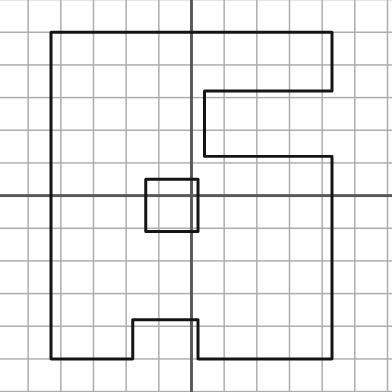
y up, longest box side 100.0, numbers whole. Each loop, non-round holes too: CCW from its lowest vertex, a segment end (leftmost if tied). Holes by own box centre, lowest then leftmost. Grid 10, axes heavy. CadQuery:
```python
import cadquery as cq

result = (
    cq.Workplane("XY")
    .moveTo(-43.0, -50.0)
    .lineTo(-18.0, -50.0)
    .lineTo(-18.0, -38.0)
    .lineTo(2.0, -38.0)
    .lineTo(2.0, -50.0)
    .lineTo(43.0, -50.0)
    .lineTo(43.0, 12.0)
    .lineTo(4.0, 12.0)
    .lineTo(4.0, 32.0)
    .lineTo(43.0, 32.0)
    .lineTo(43.0, 50.0)
    .lineTo(-43.0, 50.0)
    .close()
    .moveTo(-14.0, -11.0)
    .lineTo(2.0, -11.0)
    .lineTo(2.0, 5.0)
    .lineTo(-14.0, 5.0)
    .close()
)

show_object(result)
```